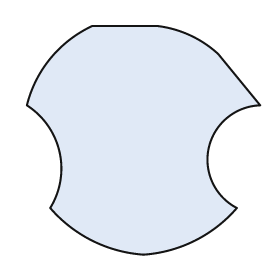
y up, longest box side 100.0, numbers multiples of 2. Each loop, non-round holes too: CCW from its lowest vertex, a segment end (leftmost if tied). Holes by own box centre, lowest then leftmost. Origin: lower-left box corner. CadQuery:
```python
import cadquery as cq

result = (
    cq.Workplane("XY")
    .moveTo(50.0, 0.0)
    .threePointArc((72.0, 6.0), (90.0, 20.0))
    .threePointArc((78.0, 46.0), (100.0, 64.0))
    .lineTo(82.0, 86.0)
    .threePointArc((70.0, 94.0), (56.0, 98.0))
    .lineTo(28.0, 98.0)
    .threePointArc((10.0, 84.0), (0.0, 64.0))
    .threePointArc((14.0, 44.0), (10.0, 20.0))
    .threePointArc((28.0, 6.0), (50.0, 0.0))
    .close()
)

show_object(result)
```